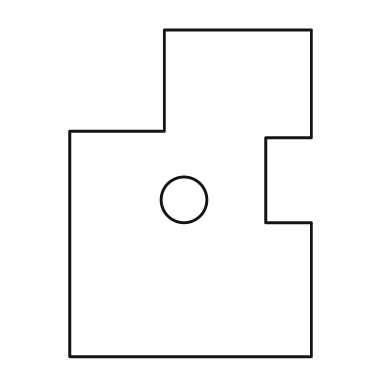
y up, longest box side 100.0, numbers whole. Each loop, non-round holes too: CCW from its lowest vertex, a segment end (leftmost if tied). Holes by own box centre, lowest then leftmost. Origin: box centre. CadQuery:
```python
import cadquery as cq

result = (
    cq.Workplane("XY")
    .moveTo(-37.0, -50.0)
    .lineTo(37.0, -50.0)
    .lineTo(37.0, -9.0)
    .lineTo(23.0, -9.0)
    .lineTo(23.0, 17.0)
    .lineTo(37.0, 17.0)
    .lineTo(37.0, 50.0)
    .lineTo(-8.0, 50.0)
    .lineTo(-8.0, 19.0)
    .lineTo(-37.0, 19.0)
    .close()
    .moveTo(-2.0, -2.0)
    .circle(7.0)
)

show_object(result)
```